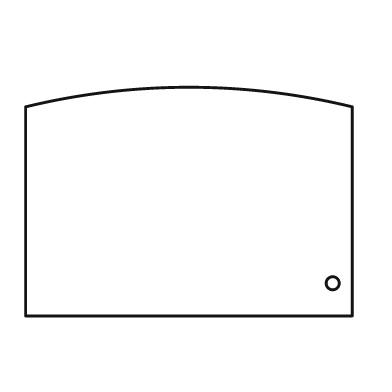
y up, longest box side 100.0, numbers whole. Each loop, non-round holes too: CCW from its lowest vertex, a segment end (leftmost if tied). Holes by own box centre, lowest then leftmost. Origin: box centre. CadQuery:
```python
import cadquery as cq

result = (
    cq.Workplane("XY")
    .moveTo(-50.0, -35.0)
    .lineTo(50.0, -35.0)
    .lineTo(50.0, 29.0)
    .threePointArc((0.0, 35.0), (-50.0, 29.0))
    .close()
    .moveTo(44.0, -25.0)
    .circle(2.0)
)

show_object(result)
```